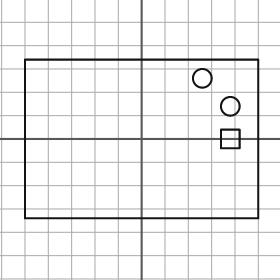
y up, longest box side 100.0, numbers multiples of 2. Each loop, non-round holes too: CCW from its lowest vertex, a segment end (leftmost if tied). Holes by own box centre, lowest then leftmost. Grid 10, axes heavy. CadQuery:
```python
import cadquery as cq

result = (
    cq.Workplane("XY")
    .moveTo(-50.0, -34.0)
    .lineTo(50.0, -34.0)
    .lineTo(50.0, 34.0)
    .lineTo(-50.0, 34.0)
    .close()
    .moveTo(34.0, -4.0)
    .lineTo(42.0, -4.0)
    .lineTo(42.0, 4.0)
    .lineTo(34.0, 4.0)
    .close()
    .moveTo(38.0, 14.0)
    .circle(4.0)
    .moveTo(26.0, 26.0)
    .circle(4.0)
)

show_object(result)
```